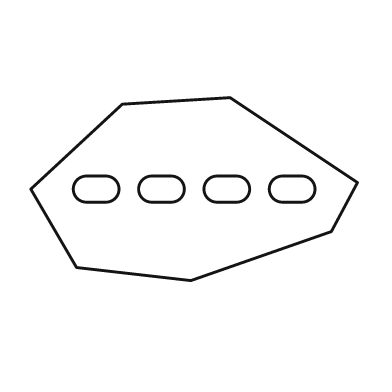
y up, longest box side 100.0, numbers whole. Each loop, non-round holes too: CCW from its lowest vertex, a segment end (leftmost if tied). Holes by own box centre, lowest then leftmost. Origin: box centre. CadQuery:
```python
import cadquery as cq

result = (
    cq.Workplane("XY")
    .moveTo(-1.0, -28.0)
    .lineTo(42.0, -13.0)
    .lineTo(50.0, 2.0)
    .lineTo(11.0, 28.0)
    .lineTo(-22.0, 26.0)
    .lineTo(-50.0, 0.0)
    .lineTo(-36.0, -24.0)
    .close()
    .moveTo(-33.0, -4.0)
    .lineTo(-27.0, -4.0)
    .threePointArc((-23.0, 0.0), (-27.0, 4.0))
    .lineTo(-33.0, 4.0)
    .threePointArc((-37.0, 0.0), (-33.0, -4.0))
    .close()
    .moveTo(-13.0, -4.0)
    .lineTo(-7.0, -4.0)
    .threePointArc((-3.0, 0.0), (-7.0, 4.0))
    .lineTo(-13.0, 4.0)
    .threePointArc((-17.0, 0.0), (-13.0, -4.0))
    .close()
    .moveTo(7.0, -4.0)
    .lineTo(13.0, -4.0)
    .threePointArc((17.0, 0.0), (13.0, 4.0))
    .lineTo(7.0, 4.0)
    .threePointArc((3.0, 0.0), (7.0, -4.0))
    .close()
    .moveTo(27.0, -4.0)
    .lineTo(33.0, -4.0)
    .threePointArc((37.0, 0.0), (33.0, 4.0))
    .lineTo(27.0, 4.0)
    .threePointArc((23.0, 0.0), (27.0, -4.0))
    .close()
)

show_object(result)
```